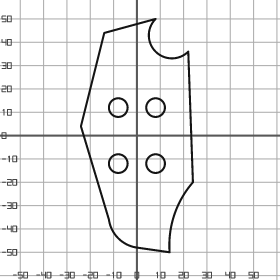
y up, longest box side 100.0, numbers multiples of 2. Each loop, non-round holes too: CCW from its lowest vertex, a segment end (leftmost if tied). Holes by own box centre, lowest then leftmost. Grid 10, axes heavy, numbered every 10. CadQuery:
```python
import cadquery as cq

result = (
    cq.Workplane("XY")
    .moveTo(14.0, -50.0)
    .threePointArc((16.0, -34.0), (24.0, -20.0))
    .lineTo(22.0, 36.0)
    .threePointArc((8.0, 36.0), (8.0, 50.0))
    .lineTo(-14.0, 44.0)
    .lineTo(-24.0, 4.0)
    .lineTo(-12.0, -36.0)
    .threePointArc((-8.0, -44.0), (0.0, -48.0))
    .close()
    .moveTo(-8.0, -12.0)
    .circle(4.0)
    .moveTo(8.0, -12.0)
    .circle(4.0)
    .moveTo(-8.0, 12.0)
    .circle(4.0)
    .moveTo(8.0, 12.0)
    .circle(4.0)
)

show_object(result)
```